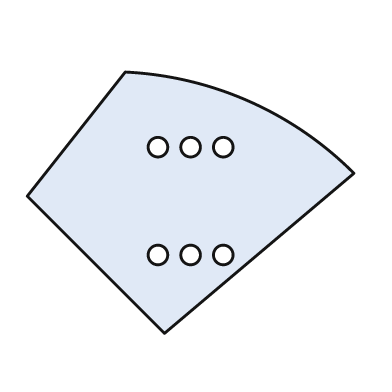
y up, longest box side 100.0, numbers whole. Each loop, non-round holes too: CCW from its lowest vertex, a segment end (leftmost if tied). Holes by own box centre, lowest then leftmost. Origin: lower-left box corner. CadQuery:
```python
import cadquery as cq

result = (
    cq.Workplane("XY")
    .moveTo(42.0, 0.0)
    .lineTo(100.0, 49.0)
    .threePointArc((68.0, 71.0), (30.0, 80.0))
    .lineTo(0.0, 42.0)
    .close()
    .moveTo(40.0, 24.0)
    .circle(3.0)
    .moveTo(50.0, 24.0)
    .circle(3.0)
    .moveTo(60.0, 24.0)
    .circle(3.0)
    .moveTo(40.0, 57.0)
    .circle(3.0)
    .moveTo(50.0, 57.0)
    .circle(3.0)
    .moveTo(60.0, 57.0)
    .circle(3.0)
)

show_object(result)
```